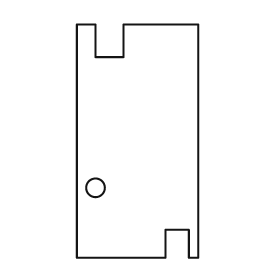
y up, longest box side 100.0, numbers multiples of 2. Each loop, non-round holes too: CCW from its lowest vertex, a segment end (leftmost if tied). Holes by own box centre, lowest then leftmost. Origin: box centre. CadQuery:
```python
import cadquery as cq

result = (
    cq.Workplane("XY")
    .moveTo(-26.0, -50.0)
    .lineTo(12.0, -50.0)
    .lineTo(12.0, -38.0)
    .lineTo(22.0, -38.0)
    .lineTo(22.0, -50.0)
    .lineTo(26.0, -50.0)
    .lineTo(26.0, 50.0)
    .lineTo(-6.0, 50.0)
    .lineTo(-6.0, 36.0)
    .lineTo(-18.0, 36.0)
    .lineTo(-18.0, 50.0)
    .lineTo(-26.0, 50.0)
    .close()
    .moveTo(-18.0, -20.0)
    .circle(4.0)
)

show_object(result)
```